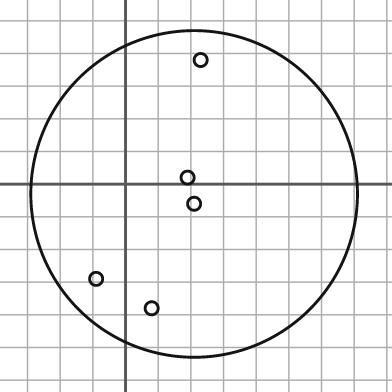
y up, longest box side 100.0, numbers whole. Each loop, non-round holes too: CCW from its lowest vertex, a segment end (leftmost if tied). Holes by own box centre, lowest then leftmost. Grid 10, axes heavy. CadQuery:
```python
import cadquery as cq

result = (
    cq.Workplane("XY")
    .moveTo(21.0, -3.0)
    .circle(50.0)
    .moveTo(8.0, -38.0)
    .circle(2.0)
    .moveTo(-9.0, -29.0)
    .circle(2.0)
    .moveTo(21.0, -6.0)
    .circle(2.0)
    .moveTo(19.0, 2.0)
    .circle(2.0)
    .moveTo(23.0, 38.0)
    .circle(2.0)
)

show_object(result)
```